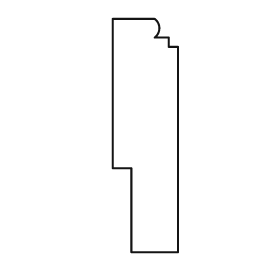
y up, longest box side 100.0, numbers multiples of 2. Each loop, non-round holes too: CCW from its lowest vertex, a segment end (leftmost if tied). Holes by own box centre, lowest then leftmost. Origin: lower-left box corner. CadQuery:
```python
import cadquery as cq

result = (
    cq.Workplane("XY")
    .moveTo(8.0, 0.0)
    .lineTo(28.0, 0.0)
    .lineTo(28.0, 88.0)
    .lineTo(24.0, 88.0)
    .lineTo(24.0, 92.0)
    .lineTo(18.0, 92.0)
    .threePointArc((20.0, 96.0), (18.0, 100.0))
    .lineTo(0.0, 100.0)
    .lineTo(0.0, 36.0)
    .lineTo(8.0, 36.0)
    .close()
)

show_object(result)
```